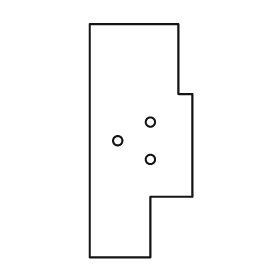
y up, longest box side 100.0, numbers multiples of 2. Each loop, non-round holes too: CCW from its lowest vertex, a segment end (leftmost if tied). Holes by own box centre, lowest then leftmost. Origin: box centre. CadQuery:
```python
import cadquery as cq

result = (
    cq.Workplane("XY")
    .moveTo(-22.0, -50.0)
    .lineTo(4.0, -50.0)
    .lineTo(4.0, -24.0)
    .lineTo(22.0, -24.0)
    .lineTo(22.0, 20.0)
    .lineTo(16.0, 20.0)
    .lineTo(16.0, 50.0)
    .lineTo(-22.0, 50.0)
    .close()
    .moveTo(4.0, -8.0)
    .circle(2.0)
    .moveTo(-10.0, 0.0)
    .circle(2.0)
    .moveTo(4.0, 8.0)
    .circle(2.0)
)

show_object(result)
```